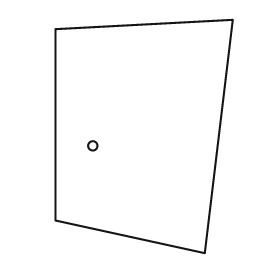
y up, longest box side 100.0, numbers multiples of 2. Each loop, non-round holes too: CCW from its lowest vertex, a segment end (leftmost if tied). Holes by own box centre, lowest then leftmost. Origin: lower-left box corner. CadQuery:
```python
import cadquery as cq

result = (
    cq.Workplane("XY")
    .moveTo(64.0, 0.0)
    .lineTo(76.0, 100.0)
    .lineTo(0.0, 96.0)
    .lineTo(0.0, 14.0)
    .close()
    .moveTo(16.0, 46.0)
    .circle(2.0)
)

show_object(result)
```